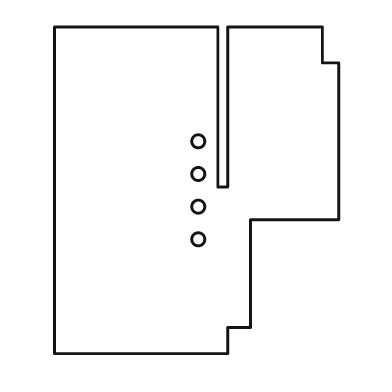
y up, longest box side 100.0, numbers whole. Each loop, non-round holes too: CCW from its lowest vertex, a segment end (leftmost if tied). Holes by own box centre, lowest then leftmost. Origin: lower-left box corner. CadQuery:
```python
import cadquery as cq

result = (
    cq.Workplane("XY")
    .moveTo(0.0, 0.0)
    .lineTo(53.0, 0.0)
    .lineTo(53.0, 8.0)
    .lineTo(60.0, 8.0)
    .lineTo(60.0, 41.0)
    .lineTo(87.0, 41.0)
    .lineTo(87.0, 89.0)
    .lineTo(82.0, 89.0)
    .lineTo(82.0, 100.0)
    .lineTo(53.0, 100.0)
    .lineTo(53.0, 51.0)
    .lineTo(50.0, 51.0)
    .lineTo(50.0, 100.0)
    .lineTo(0.0, 100.0)
    .close()
    .moveTo(44.0, 35.0)
    .circle(2.0)
    .moveTo(44.0, 45.0)
    .circle(2.0)
    .moveTo(44.0, 55.0)
    .circle(2.0)
    .moveTo(44.0, 65.0)
    .circle(2.0)
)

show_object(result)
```